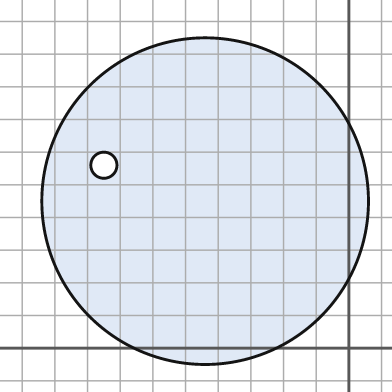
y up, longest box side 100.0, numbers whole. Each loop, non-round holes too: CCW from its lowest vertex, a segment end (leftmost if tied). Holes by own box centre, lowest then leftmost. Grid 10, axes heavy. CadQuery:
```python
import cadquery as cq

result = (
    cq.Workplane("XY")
    .moveTo(-44.0, 45.0)
    .circle(50.0)
    .moveTo(-75.0, 56.0)
    .circle(4.0)
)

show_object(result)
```